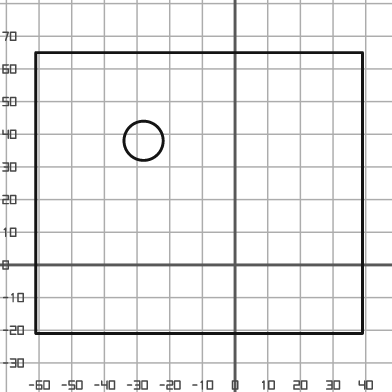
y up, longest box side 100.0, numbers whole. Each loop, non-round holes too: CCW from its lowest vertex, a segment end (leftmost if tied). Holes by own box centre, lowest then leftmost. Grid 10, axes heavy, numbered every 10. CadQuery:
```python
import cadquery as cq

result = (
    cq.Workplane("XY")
    .moveTo(-61.0, -21.0)
    .lineTo(39.0, -21.0)
    .lineTo(39.0, 65.0)
    .lineTo(-61.0, 65.0)
    .close()
    .moveTo(-28.0, 38.0)
    .circle(6.0)
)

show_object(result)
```